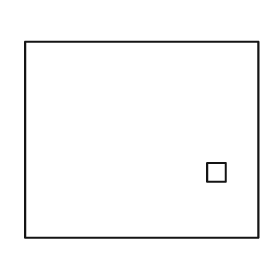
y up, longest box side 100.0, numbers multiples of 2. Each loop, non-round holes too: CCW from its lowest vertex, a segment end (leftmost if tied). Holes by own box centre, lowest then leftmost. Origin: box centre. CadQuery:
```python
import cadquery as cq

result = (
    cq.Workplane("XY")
    .moveTo(-50.0, -42.0)
    .lineTo(50.0, -42.0)
    .lineTo(50.0, 42.0)
    .lineTo(-50.0, 42.0)
    .close()
    .moveTo(28.0, -18.0)
    .lineTo(36.0, -18.0)
    .lineTo(36.0, -10.0)
    .lineTo(28.0, -10.0)
    .close()
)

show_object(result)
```